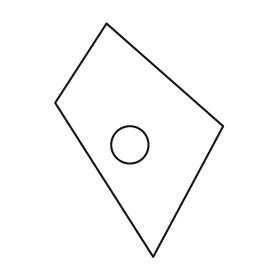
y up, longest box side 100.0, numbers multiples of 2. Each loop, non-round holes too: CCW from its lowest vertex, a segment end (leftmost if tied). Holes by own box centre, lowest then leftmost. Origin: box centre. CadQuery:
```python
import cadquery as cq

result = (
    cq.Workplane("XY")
    .moveTo(6.0, -50.0)
    .lineTo(36.0, 6.0)
    .lineTo(-14.0, 50.0)
    .lineTo(-36.0, 16.0)
    .close()
    .moveTo(-4.0, -2.0)
    .circle(8.0)
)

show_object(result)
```